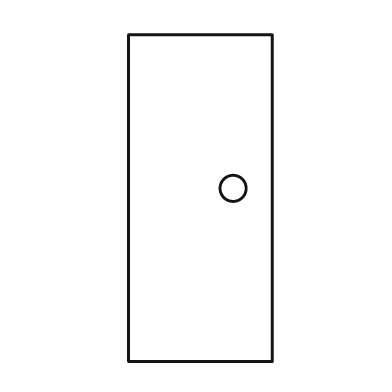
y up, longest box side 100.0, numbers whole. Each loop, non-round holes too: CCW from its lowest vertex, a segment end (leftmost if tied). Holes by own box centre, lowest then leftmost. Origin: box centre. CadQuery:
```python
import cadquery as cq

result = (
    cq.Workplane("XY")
    .moveTo(-22.0, -50.0)
    .lineTo(22.0, -50.0)
    .lineTo(22.0, 50.0)
    .lineTo(-22.0, 50.0)
    .close()
    .moveTo(10.0, 3.0)
    .circle(4.0)
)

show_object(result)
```